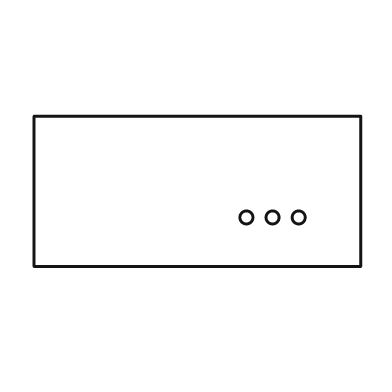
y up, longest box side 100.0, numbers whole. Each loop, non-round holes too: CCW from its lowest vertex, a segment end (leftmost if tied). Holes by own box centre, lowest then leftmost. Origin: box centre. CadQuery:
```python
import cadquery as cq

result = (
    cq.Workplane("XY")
    .moveTo(-50.0, -23.0)
    .lineTo(50.0, -23.0)
    .lineTo(50.0, 23.0)
    .lineTo(-50.0, 23.0)
    .close()
    .moveTo(15.0, -8.0)
    .circle(2.0)
    .moveTo(23.0, -8.0)
    .circle(2.0)
    .moveTo(31.0, -8.0)
    .circle(2.0)
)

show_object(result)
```